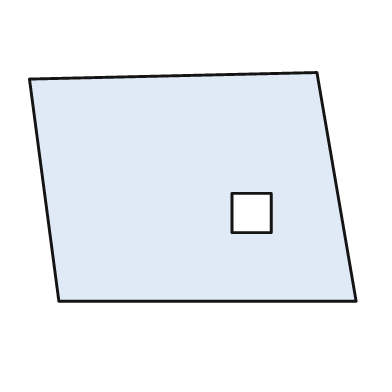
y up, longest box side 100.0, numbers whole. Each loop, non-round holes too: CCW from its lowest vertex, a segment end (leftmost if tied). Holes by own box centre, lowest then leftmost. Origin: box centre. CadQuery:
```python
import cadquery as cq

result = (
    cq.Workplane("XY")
    .moveTo(-41.0, -35.0)
    .lineTo(50.0, -35.0)
    .lineTo(38.0, 35.0)
    .lineTo(-50.0, 33.0)
    .close()
    .moveTo(12.0, -14.0)
    .lineTo(24.0, -14.0)
    .lineTo(24.0, -2.0)
    .lineTo(12.0, -2.0)
    .close()
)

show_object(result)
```